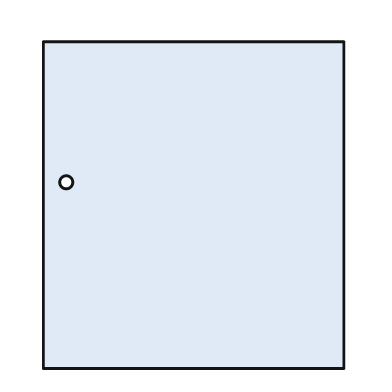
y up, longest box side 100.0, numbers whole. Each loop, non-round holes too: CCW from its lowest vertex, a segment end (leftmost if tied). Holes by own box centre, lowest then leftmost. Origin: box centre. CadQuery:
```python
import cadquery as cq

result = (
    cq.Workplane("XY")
    .moveTo(-46.0, -50.0)
    .lineTo(46.0, -50.0)
    .lineTo(46.0, 50.0)
    .lineTo(-46.0, 50.0)
    .close()
    .moveTo(-39.0, 7.0)
    .circle(2.0)
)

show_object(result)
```